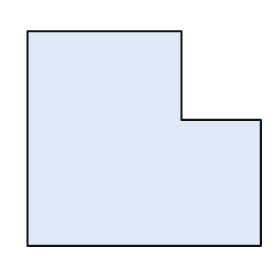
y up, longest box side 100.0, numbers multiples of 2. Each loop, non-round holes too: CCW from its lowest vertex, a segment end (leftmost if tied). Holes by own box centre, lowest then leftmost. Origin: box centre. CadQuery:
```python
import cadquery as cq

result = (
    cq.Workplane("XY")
    .moveTo(-50.0, -46.0)
    .lineTo(50.0, -46.0)
    .lineTo(50.0, 8.0)
    .lineTo(16.0, 8.0)
    .lineTo(16.0, 46.0)
    .lineTo(-50.0, 46.0)
    .close()
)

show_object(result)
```